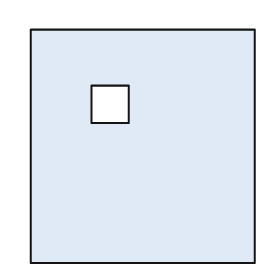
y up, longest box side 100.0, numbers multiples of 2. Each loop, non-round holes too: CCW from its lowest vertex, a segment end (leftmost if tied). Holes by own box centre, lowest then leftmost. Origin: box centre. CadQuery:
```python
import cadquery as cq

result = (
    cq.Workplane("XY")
    .moveTo(-48.0, -50.0)
    .lineTo(48.0, -50.0)
    .lineTo(48.0, 50.0)
    .lineTo(-48.0, 50.0)
    .close()
    .moveTo(-22.0, 10.0)
    .lineTo(-6.0, 10.0)
    .lineTo(-6.0, 26.0)
    .lineTo(-22.0, 26.0)
    .close()
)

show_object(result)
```